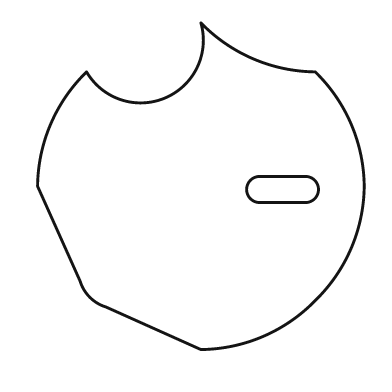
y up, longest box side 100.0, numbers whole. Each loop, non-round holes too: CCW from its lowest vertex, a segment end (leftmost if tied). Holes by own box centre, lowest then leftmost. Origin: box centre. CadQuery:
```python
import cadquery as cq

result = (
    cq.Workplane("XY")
    .moveTo(0.0, -50.0)
    .threePointArc((19.0, -46.0), (35.0, -35.0))
    .threePointArc((46.0, -19.0), (50.0, 0.0))
    .threePointArc((46.0, 19.0), (35.0, 35.0))
    .threePointArc((16.0, 39.0), (0.0, 50.0))
    .threePointArc((-11.0, 27.0), (-35.0, 35.0))
    .threePointArc((-46.0, 19.0), (-50.0, 0.0))
    .lineTo(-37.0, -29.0)
    .threePointArc((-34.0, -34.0), (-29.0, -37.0))
    .close()
    .moveTo(18.0, -5.0)
    .lineTo(32.0, -5.0)
    .threePointArc((36.0, -1.0), (32.0, 3.0))
    .lineTo(18.0, 3.0)
    .threePointArc((14.0, -1.0), (18.0, -5.0))
    .close()
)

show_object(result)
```